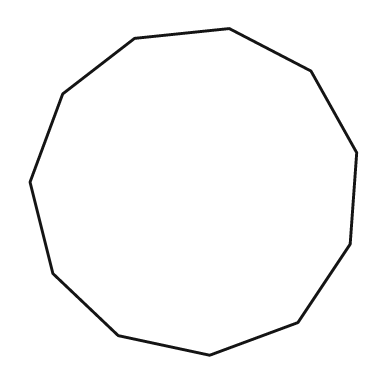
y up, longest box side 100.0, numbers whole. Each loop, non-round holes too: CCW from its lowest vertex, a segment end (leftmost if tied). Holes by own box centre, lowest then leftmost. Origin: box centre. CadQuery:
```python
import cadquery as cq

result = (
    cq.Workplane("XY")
    .moveTo(5.0, -50.0)
    .lineTo(32.0, -40.0)
    .lineTo(48.0, -16.0)
    .lineTo(50.0, 12.0)
    .lineTo(36.0, 37.0)
    .lineTo(11.0, 50.0)
    .lineTo(-18.0, 47.0)
    .lineTo(-40.0, 30.0)
    .lineTo(-50.0, 3.0)
    .lineTo(-43.0, -25.0)
    .lineTo(-23.0, -44.0)
    .close()
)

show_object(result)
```